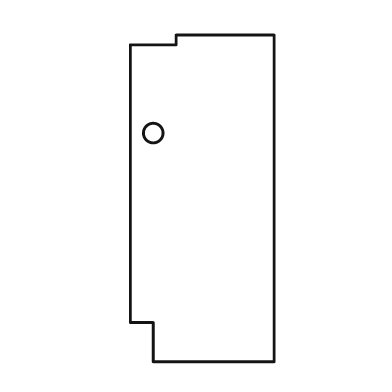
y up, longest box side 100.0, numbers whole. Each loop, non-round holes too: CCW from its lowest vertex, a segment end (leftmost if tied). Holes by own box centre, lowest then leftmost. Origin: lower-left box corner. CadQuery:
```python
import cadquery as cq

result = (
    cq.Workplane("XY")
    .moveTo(7.0, 0.0)
    .lineTo(44.0, 0.0)
    .lineTo(44.0, 100.0)
    .lineTo(14.0, 100.0)
    .lineTo(14.0, 97.0)
    .lineTo(0.0, 97.0)
    .lineTo(0.0, 12.0)
    .lineTo(7.0, 12.0)
    .close()
    .moveTo(7.0, 70.0)
    .circle(3.0)
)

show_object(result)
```